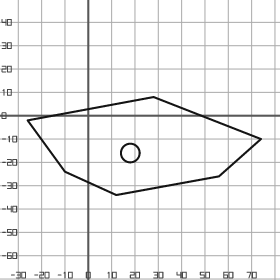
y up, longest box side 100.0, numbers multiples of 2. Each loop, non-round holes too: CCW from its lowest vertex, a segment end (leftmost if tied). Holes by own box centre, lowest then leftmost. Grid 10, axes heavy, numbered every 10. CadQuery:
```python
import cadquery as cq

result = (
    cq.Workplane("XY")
    .moveTo(12.0, -34.0)
    .lineTo(56.0, -26.0)
    .lineTo(74.0, -10.0)
    .lineTo(28.0, 8.0)
    .lineTo(-26.0, -2.0)
    .lineTo(-10.0, -24.0)
    .close()
    .moveTo(18.0, -16.0)
    .circle(4.0)
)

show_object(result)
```